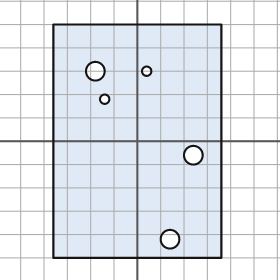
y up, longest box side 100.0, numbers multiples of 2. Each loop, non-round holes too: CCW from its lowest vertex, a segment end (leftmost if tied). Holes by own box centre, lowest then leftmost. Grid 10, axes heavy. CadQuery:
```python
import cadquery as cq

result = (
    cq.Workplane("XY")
    .moveTo(-36.0, -50.0)
    .lineTo(36.0, -50.0)
    .lineTo(36.0, 50.0)
    .lineTo(-36.0, 50.0)
    .close()
    .moveTo(14.0, -42.0)
    .circle(4.0)
    .moveTo(24.0, -6.0)
    .circle(4.0)
    .moveTo(-14.0, 18.0)
    .circle(2.0)
    .moveTo(-18.0, 30.0)
    .circle(4.0)
    .moveTo(4.0, 30.0)
    .circle(2.0)
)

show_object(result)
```